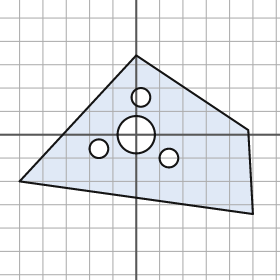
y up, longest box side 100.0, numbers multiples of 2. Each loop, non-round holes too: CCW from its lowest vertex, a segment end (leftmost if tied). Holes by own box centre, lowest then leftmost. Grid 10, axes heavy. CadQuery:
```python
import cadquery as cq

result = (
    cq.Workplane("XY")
    .moveTo(50.0, -34.0)
    .lineTo(48.0, 2.0)
    .lineTo(0.0, 34.0)
    .lineTo(-50.0, -20.0)
    .close()
    .moveTo(14.0, -10.0)
    .circle(4.0)
    .moveTo(-16.0, -6.0)
    .circle(4.0)
    .moveTo(0.0, 0.0)
    .circle(8.0)
    .moveTo(2.0, 16.0)
    .circle(4.0)
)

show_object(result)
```